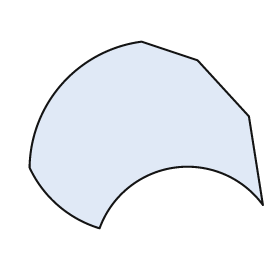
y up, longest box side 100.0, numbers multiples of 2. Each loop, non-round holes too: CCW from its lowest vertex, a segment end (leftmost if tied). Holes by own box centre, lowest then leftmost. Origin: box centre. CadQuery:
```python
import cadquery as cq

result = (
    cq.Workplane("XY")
    .moveTo(-20.0, -40.0)
    .threePointArc((12.0, -14.0), (50.0, -30.0))
    .lineTo(44.0, 8.0)
    .lineTo(22.0, 32.0)
    .lineTo(-2.0, 40.0)
    .threePointArc((-36.0, 22.0), (-50.0, -14.0))
    .threePointArc((-38.0, -30.0), (-20.0, -40.0))
    .close()
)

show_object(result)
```